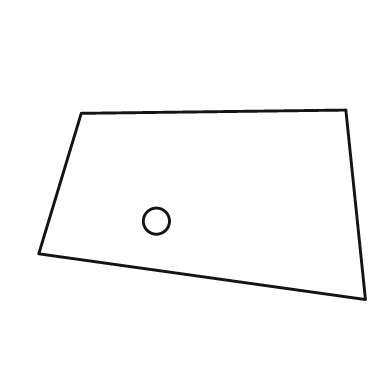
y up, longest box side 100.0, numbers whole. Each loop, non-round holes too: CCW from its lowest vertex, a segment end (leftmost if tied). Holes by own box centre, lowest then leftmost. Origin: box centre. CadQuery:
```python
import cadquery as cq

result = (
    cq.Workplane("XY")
    .moveTo(50.0, -29.0)
    .lineTo(44.0, 29.0)
    .lineTo(-37.0, 28.0)
    .lineTo(-50.0, -15.0)
    .close()
    .moveTo(-14.0, -5.0)
    .circle(4.0)
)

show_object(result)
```